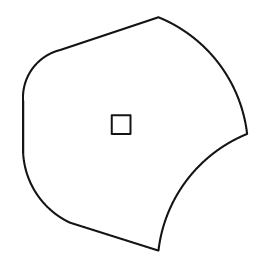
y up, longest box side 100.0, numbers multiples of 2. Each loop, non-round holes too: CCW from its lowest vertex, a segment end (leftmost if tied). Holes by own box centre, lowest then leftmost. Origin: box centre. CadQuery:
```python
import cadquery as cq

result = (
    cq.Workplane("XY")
    .moveTo(10.0, -50.0)
    .threePointArc((22.0, -20.0), (48.0, 0.0))
    .threePointArc((36.0, 30.0), (10.0, 50.0))
    .lineTo(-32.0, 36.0)
    .threePointArc((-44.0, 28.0), (-48.0, 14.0))
    .lineTo(-48.0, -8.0)
    .threePointArc((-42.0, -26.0), (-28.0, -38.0))
    .close()
    .moveTo(-10.0, 0.0)
    .lineTo(-2.0, 0.0)
    .lineTo(-2.0, 8.0)
    .lineTo(-10.0, 8.0)
    .close()
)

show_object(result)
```